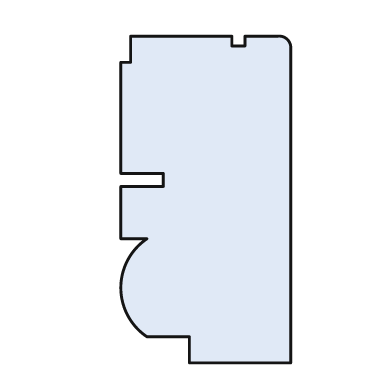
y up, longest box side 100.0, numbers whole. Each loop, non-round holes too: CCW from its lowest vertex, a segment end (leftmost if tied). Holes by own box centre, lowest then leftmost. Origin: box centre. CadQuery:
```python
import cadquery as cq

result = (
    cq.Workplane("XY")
    .moveTo(-5.0, -50.0)
    .lineTo(26.0, -50.0)
    .lineTo(26.0, 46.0)
    .threePointArc((25.0, 49.0), (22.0, 50.0))
    .lineTo(12.0, 50.0)
    .lineTo(12.0, 47.0)
    .lineTo(8.0, 47.0)
    .lineTo(8.0, 50.0)
    .lineTo(-23.0, 50.0)
    .lineTo(-23.0, 42.0)
    .lineTo(-26.0, 42.0)
    .lineTo(-26.0, 8.0)
    .lineTo(-13.0, 8.0)
    .lineTo(-13.0, 4.0)
    .lineTo(-26.0, 4.0)
    .lineTo(-26.0, -12.0)
    .lineTo(-18.0, -12.0)
    .threePointArc((-26.0, -27.0), (-18.0, -42.0))
    .lineTo(-5.0, -42.0)
    .close()
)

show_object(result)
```